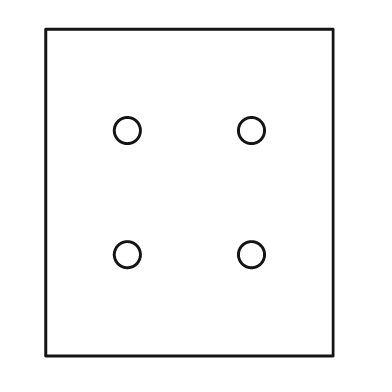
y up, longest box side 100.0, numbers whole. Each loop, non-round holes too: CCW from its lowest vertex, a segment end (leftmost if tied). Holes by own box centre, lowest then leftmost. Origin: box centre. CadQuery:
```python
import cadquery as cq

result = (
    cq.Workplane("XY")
    .moveTo(-44.0, -50.0)
    .lineTo(44.0, -50.0)
    .lineTo(44.0, 50.0)
    .lineTo(-44.0, 50.0)
    .close()
    .moveTo(-19.0, -19.0)
    .circle(4.0)
    .moveTo(19.0, -19.0)
    .circle(4.0)
    .moveTo(-19.0, 19.0)
    .circle(4.0)
    .moveTo(19.0, 19.0)
    .circle(4.0)
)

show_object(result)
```